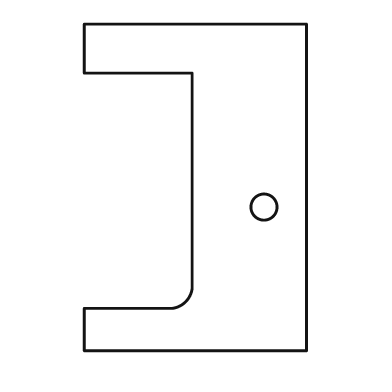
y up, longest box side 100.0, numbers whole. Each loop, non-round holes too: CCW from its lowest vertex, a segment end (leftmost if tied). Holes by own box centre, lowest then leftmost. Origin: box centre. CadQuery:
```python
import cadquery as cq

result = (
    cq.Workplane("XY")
    .moveTo(-34.0, -50.0)
    .lineTo(34.0, -50.0)
    .lineTo(34.0, 50.0)
    .lineTo(-34.0, 50.0)
    .lineTo(-34.0, 35.0)
    .lineTo(-1.0, 35.0)
    .lineTo(-1.0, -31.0)
    .threePointArc((-3.0, -35.0), (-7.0, -37.0))
    .lineTo(-34.0, -37.0)
    .close()
    .moveTo(21.0, -6.0)
    .circle(4.0)
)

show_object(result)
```